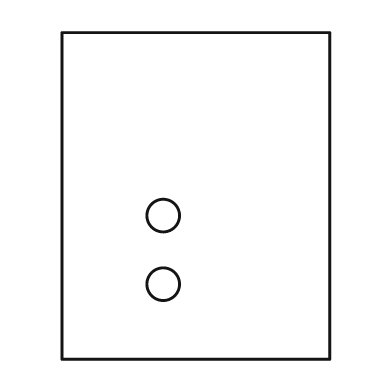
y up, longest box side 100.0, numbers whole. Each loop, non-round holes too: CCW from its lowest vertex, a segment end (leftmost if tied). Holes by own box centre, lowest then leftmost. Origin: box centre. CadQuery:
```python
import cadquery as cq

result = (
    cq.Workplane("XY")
    .moveTo(-41.0, -50.0)
    .lineTo(41.0, -50.0)
    .lineTo(41.0, 50.0)
    .lineTo(-41.0, 50.0)
    .close()
    .moveTo(-10.0, -27.0)
    .circle(5.0)
    .moveTo(-10.0, -6.0)
    .circle(5.0)
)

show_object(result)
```